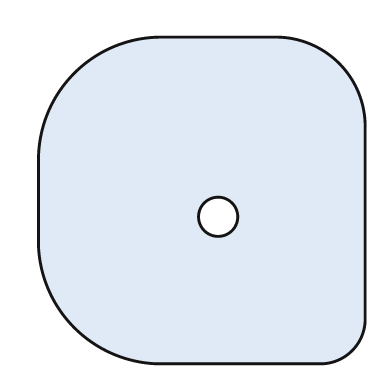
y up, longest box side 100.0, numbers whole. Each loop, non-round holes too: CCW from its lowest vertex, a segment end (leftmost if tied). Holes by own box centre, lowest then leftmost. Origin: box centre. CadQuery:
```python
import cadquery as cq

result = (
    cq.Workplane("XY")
    .moveTo(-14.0, -50.0)
    .lineTo(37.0, -50.0)
    .threePointArc((46.0, -46.0), (50.0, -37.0))
    .lineTo(50.0, 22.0)
    .threePointArc((42.0, 42.0), (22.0, 50.0))
    .lineTo(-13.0, 50.0)
    .threePointArc((-39.0, 39.0), (-50.0, 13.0))
    .lineTo(-50.0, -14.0)
    .threePointArc((-39.0, -39.0), (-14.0, -50.0))
    .close()
    .moveTo(5.0, -5.0)
    .circle(6.0)
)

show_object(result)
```